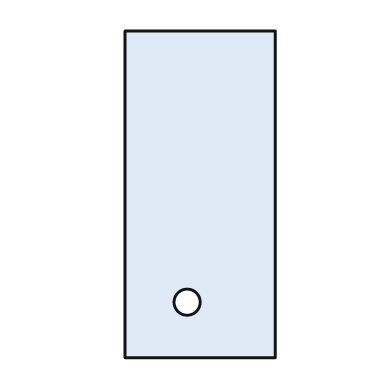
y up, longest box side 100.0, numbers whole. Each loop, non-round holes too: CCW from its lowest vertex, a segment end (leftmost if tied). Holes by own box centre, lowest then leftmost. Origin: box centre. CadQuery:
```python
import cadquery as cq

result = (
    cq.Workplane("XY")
    .moveTo(-23.0, -50.0)
    .lineTo(23.0, -50.0)
    .lineTo(23.0, 50.0)
    .lineTo(-23.0, 50.0)
    .close()
    .moveTo(-4.0, -33.0)
    .circle(4.0)
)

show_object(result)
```